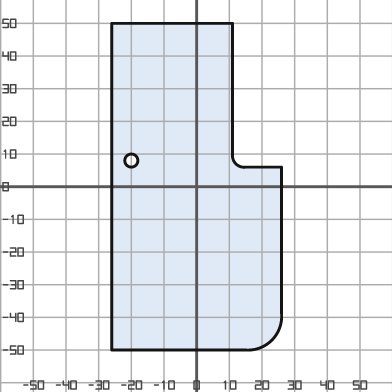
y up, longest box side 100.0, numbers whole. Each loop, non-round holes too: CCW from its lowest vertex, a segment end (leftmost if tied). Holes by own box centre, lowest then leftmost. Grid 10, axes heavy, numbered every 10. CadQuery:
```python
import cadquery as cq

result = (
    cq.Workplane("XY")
    .moveTo(-26.0, -50.0)
    .lineTo(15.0, -50.0)
    .threePointArc((23.0, -47.0), (26.0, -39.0))
    .lineTo(26.0, 6.0)
    .lineTo(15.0, 6.0)
    .threePointArc((12.0, 7.0), (11.0, 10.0))
    .lineTo(11.0, 50.0)
    .lineTo(-26.0, 50.0)
    .close()
    .moveTo(-20.0, 8.0)
    .circle(2.0)
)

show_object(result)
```